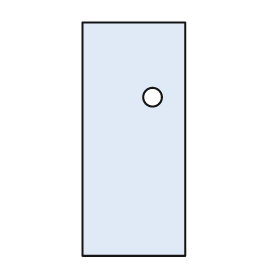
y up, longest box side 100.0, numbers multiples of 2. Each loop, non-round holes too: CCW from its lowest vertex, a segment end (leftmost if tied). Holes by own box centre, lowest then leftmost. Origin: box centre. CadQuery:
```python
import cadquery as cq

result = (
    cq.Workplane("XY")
    .moveTo(-22.0, -50.0)
    .lineTo(22.0, -50.0)
    .lineTo(22.0, 50.0)
    .lineTo(-22.0, 50.0)
    .close()
    .moveTo(8.0, 18.0)
    .circle(4.0)
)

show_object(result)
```